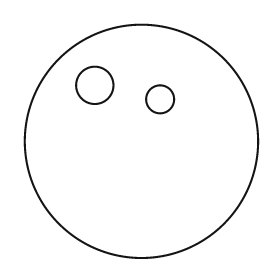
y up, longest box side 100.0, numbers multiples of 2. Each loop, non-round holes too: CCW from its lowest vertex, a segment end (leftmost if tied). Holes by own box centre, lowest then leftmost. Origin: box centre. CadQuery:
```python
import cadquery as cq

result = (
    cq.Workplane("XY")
    .moveTo(0.0, 0.0)
    .circle(50.0)
    .moveTo(8.0, 18.0)
    .circle(6.0)
    .moveTo(-20.0, 24.0)
    .circle(8.0)
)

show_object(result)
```